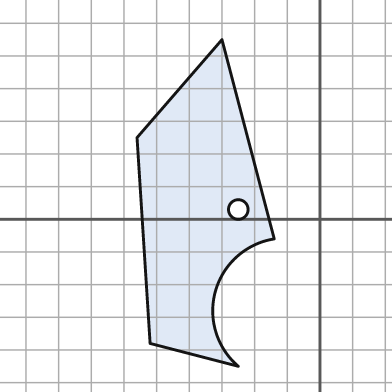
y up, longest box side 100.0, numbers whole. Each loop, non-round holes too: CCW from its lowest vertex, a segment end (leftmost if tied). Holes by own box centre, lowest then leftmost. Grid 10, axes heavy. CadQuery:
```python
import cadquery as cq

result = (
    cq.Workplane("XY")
    .moveTo(-25.0, -45.0)
    .threePointArc((-32.0, -22.0), (-14.0, -6.0))
    .lineTo(-30.0, 55.0)
    .lineTo(-56.0, 25.0)
    .lineTo(-52.0, -38.0)
    .close()
    .moveTo(-25.0, 3.0)
    .circle(3.0)
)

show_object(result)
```